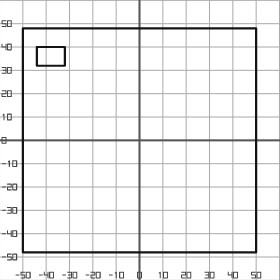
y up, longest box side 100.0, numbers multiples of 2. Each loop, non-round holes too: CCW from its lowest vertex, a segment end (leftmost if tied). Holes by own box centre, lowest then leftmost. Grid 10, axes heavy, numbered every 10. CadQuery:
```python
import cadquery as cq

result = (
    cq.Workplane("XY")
    .moveTo(-50.0, -48.0)
    .lineTo(50.0, -48.0)
    .lineTo(50.0, 48.0)
    .lineTo(-50.0, 48.0)
    .close()
    .moveTo(-44.0, 32.0)
    .lineTo(-32.0, 32.0)
    .lineTo(-32.0, 40.0)
    .lineTo(-44.0, 40.0)
    .close()
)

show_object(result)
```